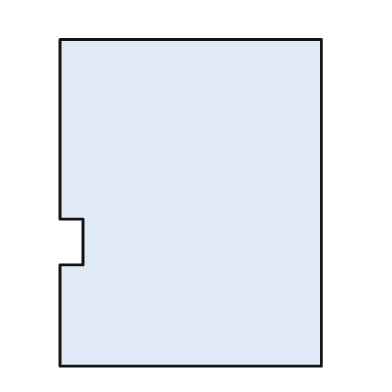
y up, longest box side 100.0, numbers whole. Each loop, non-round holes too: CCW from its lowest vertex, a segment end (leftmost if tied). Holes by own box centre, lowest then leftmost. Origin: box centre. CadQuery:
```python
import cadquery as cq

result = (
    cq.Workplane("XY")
    .moveTo(-40.0, -50.0)
    .lineTo(40.0, -50.0)
    .lineTo(40.0, 50.0)
    .lineTo(-40.0, 50.0)
    .lineTo(-40.0, -5.0)
    .lineTo(-33.0, -5.0)
    .lineTo(-33.0, -19.0)
    .lineTo(-40.0, -19.0)
    .close()
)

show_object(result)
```